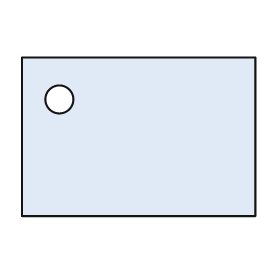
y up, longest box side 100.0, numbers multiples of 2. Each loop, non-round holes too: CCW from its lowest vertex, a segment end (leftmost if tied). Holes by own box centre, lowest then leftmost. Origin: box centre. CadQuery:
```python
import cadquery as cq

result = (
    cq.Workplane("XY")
    .moveTo(-50.0, -34.0)
    .lineTo(50.0, -34.0)
    .lineTo(50.0, 34.0)
    .lineTo(-50.0, 34.0)
    .close()
    .moveTo(-34.0, 16.0)
    .circle(6.0)
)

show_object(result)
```